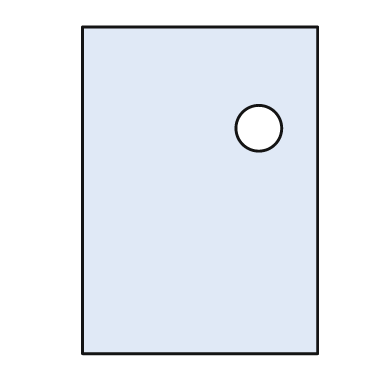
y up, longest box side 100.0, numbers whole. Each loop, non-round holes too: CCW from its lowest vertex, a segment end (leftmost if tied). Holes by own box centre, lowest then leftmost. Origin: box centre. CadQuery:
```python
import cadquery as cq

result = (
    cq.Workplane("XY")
    .moveTo(-36.0, -50.0)
    .lineTo(36.0, -50.0)
    .lineTo(36.0, 50.0)
    .lineTo(-36.0, 50.0)
    .close()
    .moveTo(18.0, 19.0)
    .circle(7.0)
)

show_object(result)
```